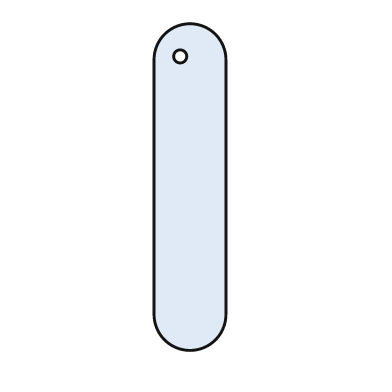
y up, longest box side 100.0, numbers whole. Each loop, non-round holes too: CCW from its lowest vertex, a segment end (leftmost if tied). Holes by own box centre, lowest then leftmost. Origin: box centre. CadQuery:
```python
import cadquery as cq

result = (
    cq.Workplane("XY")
    .moveTo(-11.0, -39.0)
    .threePointArc((0.0, -50.0), (11.0, -39.0))
    .lineTo(11.0, 39.0)
    .threePointArc((0.0, 50.0), (-11.0, 39.0))
    .close()
    .moveTo(-3.0, 40.0)
    .circle(2.0)
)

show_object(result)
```